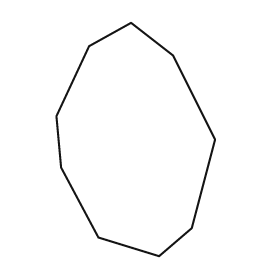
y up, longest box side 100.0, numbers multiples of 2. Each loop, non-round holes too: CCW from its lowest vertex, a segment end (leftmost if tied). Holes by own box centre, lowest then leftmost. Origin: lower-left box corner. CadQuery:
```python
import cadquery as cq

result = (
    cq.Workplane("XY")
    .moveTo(44.0, 0.0)
    .lineTo(58.0, 12.0)
    .lineTo(68.0, 50.0)
    .lineTo(50.0, 86.0)
    .lineTo(32.0, 100.0)
    .lineTo(14.0, 90.0)
    .lineTo(0.0, 60.0)
    .lineTo(2.0, 38.0)
    .lineTo(18.0, 8.0)
    .close()
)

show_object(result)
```